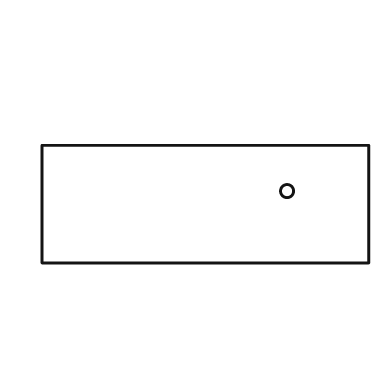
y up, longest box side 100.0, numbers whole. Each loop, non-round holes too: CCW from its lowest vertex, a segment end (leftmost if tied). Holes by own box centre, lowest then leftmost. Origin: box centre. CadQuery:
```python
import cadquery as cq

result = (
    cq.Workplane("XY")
    .moveTo(-50.0, -18.0)
    .lineTo(50.0, -18.0)
    .lineTo(50.0, 18.0)
    .lineTo(-50.0, 18.0)
    .close()
    .moveTo(25.0, 4.0)
    .circle(2.0)
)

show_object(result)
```